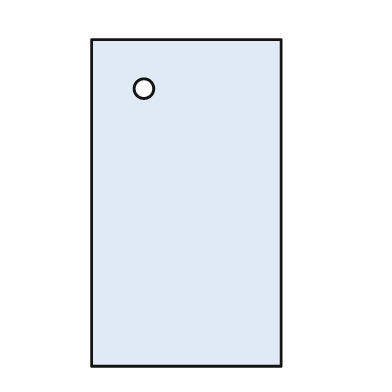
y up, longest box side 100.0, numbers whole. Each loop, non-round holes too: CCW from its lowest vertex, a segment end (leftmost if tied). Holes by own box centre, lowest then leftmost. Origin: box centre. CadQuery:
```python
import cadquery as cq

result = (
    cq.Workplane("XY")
    .moveTo(-29.0, -50.0)
    .lineTo(29.0, -50.0)
    .lineTo(29.0, 50.0)
    .lineTo(-29.0, 50.0)
    .close()
    .moveTo(-13.0, 35.0)
    .circle(3.0)
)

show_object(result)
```